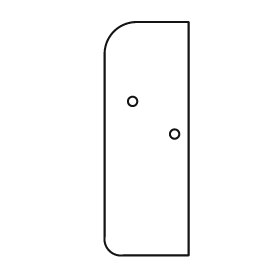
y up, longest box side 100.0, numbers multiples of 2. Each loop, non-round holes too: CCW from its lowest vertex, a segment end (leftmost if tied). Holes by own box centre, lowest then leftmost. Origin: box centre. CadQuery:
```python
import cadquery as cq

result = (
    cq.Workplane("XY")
    .moveTo(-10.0, -50.0)
    .lineTo(18.0, -50.0)
    .lineTo(18.0, 50.0)
    .lineTo(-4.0, 50.0)
    .threePointArc((-14.0, 46.0), (-18.0, 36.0))
    .lineTo(-18.0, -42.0)
    .threePointArc((-16.0, -48.0), (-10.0, -50.0))
    .close()
    .moveTo(12.0, 2.0)
    .circle(2.0)
    .moveTo(-6.0, 16.0)
    .circle(2.0)
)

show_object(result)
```